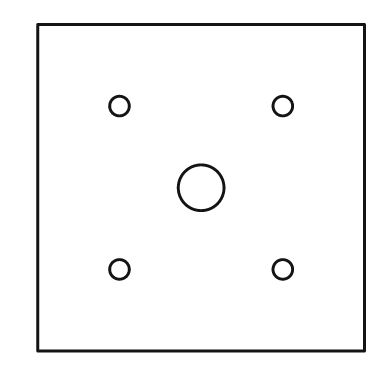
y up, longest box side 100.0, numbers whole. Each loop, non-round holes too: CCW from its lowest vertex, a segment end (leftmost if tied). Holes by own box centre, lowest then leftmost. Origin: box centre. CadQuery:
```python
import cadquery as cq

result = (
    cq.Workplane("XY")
    .moveTo(-50.0, -50.0)
    .lineTo(50.0, -50.0)
    .lineTo(50.0, 50.0)
    .lineTo(-50.0, 50.0)
    .close()
    .moveTo(-25.0, -25.0)
    .circle(3.0)
    .moveTo(25.0, -25.0)
    .circle(3.0)
    .moveTo(0.0, 0.0)
    .circle(7.0)
    .moveTo(-25.0, 25.0)
    .circle(3.0)
    .moveTo(25.0, 25.0)
    .circle(3.0)
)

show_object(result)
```